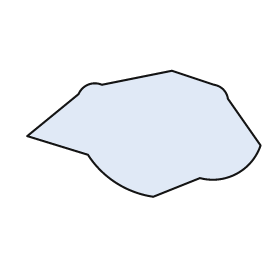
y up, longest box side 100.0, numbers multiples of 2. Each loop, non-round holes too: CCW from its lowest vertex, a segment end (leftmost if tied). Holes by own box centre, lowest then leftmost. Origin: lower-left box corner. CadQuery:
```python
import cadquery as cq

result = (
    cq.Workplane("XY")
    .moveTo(54.0, 0.0)
    .lineTo(74.0, 8.0)
    .threePointArc((90.0, 10.0), (100.0, 22.0))
    .lineTo(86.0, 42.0)
    .threePointArc((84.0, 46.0), (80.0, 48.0))
    .lineTo(62.0, 54.0)
    .lineTo(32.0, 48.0)
    .threePointArc((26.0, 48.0), (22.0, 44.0))
    .lineTo(0.0, 26.0)
    .lineTo(26.0, 18.0)
    .threePointArc((38.0, 6.0), (54.0, 0.0))
    .close()
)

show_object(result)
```